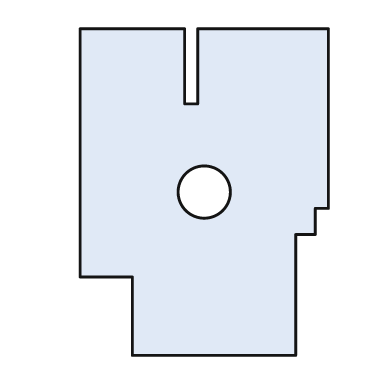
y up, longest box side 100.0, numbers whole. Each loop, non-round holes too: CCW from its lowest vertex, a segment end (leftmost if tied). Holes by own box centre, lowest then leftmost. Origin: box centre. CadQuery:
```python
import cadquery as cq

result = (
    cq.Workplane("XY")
    .moveTo(-22.0, -50.0)
    .lineTo(28.0, -50.0)
    .lineTo(28.0, -13.0)
    .lineTo(34.0, -13.0)
    .lineTo(34.0, -5.0)
    .lineTo(38.0, -5.0)
    .lineTo(38.0, 50.0)
    .lineTo(-2.0, 50.0)
    .lineTo(-2.0, 27.0)
    .lineTo(-6.0, 27.0)
    .lineTo(-6.0, 50.0)
    .lineTo(-38.0, 50.0)
    .lineTo(-38.0, -26.0)
    .lineTo(-22.0, -26.0)
    .close()
    .moveTo(0.0, 0.0)
    .circle(8.0)
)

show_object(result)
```